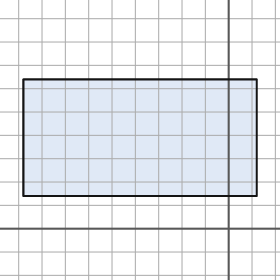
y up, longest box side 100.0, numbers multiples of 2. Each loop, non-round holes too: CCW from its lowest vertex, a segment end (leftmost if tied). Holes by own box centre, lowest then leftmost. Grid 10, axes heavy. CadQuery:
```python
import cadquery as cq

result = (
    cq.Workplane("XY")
    .moveTo(-88.0, 14.0)
    .lineTo(12.0, 14.0)
    .lineTo(12.0, 64.0)
    .lineTo(-88.0, 64.0)
    .close()
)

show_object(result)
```